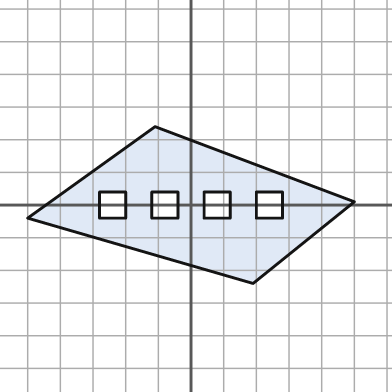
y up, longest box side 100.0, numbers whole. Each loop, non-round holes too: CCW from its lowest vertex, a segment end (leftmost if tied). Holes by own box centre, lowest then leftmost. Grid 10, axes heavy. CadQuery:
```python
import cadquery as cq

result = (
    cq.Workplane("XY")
    .moveTo(19.0, -24.0)
    .lineTo(50.0, 1.0)
    .lineTo(-11.0, 24.0)
    .lineTo(-50.0, -4.0)
    .close()
    .moveTo(-28.0, -4.0)
    .lineTo(-20.0, -4.0)
    .lineTo(-20.0, 4.0)
    .lineTo(-28.0, 4.0)
    .close()
    .moveTo(-12.0, -4.0)
    .lineTo(-4.0, -4.0)
    .lineTo(-4.0, 4.0)
    .lineTo(-12.0, 4.0)
    .close()
    .moveTo(4.0, -4.0)
    .lineTo(12.0, -4.0)
    .lineTo(12.0, 4.0)
    .lineTo(4.0, 4.0)
    .close()
    .moveTo(20.0, -4.0)
    .lineTo(28.0, -4.0)
    .lineTo(28.0, 4.0)
    .lineTo(20.0, 4.0)
    .close()
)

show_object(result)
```